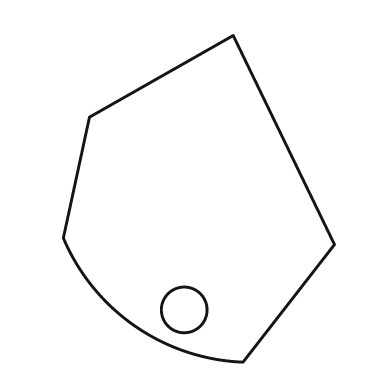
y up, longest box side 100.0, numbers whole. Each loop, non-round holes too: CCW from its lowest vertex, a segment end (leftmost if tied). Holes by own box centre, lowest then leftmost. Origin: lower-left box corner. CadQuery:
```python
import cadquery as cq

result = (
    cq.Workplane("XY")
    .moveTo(55.0, 0.0)
    .lineTo(83.0, 36.0)
    .lineTo(52.0, 100.0)
    .lineTo(8.0, 75.0)
    .lineTo(0.0, 38.0)
    .threePointArc((22.0, 11.0), (55.0, 0.0))
    .close()
    .moveTo(37.0, 16.0)
    .circle(7.0)
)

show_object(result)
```